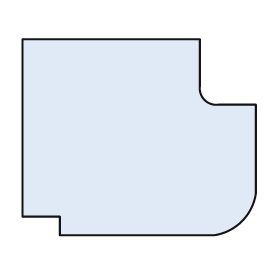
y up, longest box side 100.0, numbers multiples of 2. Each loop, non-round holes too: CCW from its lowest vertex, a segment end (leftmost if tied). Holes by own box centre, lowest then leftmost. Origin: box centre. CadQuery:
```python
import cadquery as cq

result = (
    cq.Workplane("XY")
    .moveTo(-34.0, -42.0)
    .lineTo(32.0, -42.0)
    .threePointArc((44.0, -36.0), (50.0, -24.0))
    .lineTo(50.0, 14.0)
    .lineTo(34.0, 14.0)
    .threePointArc((28.0, 16.0), (26.0, 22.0))
    .lineTo(26.0, 42.0)
    .lineTo(-50.0, 42.0)
    .lineTo(-50.0, -34.0)
    .lineTo(-34.0, -34.0)
    .close()
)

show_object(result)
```